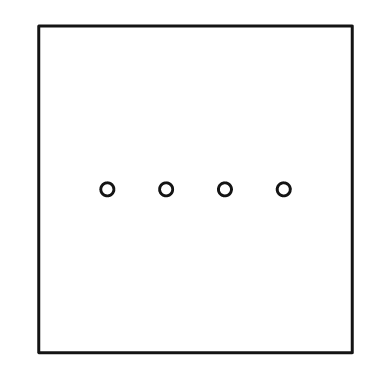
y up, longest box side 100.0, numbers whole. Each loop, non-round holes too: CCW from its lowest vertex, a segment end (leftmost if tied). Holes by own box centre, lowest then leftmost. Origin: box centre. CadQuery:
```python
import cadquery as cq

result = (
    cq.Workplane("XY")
    .moveTo(-48.0, -50.0)
    .lineTo(48.0, -50.0)
    .lineTo(48.0, 50.0)
    .lineTo(-48.0, 50.0)
    .close()
    .moveTo(-27.0, 0.0)
    .circle(2.0)
    .moveTo(-9.0, 0.0)
    .circle(2.0)
    .moveTo(9.0, 0.0)
    .circle(2.0)
    .moveTo(27.0, 0.0)
    .circle(2.0)
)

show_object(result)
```